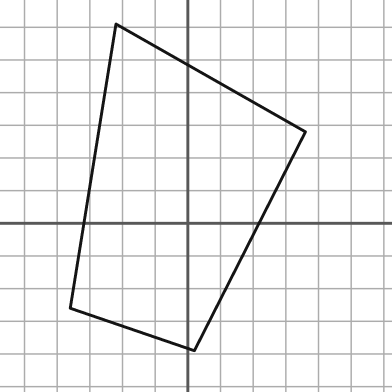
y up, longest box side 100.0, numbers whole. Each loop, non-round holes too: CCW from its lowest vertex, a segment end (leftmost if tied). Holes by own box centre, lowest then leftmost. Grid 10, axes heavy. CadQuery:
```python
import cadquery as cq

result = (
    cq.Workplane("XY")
    .moveTo(2.0, -39.0)
    .lineTo(36.0, 28.0)
    .lineTo(-22.0, 61.0)
    .lineTo(-36.0, -26.0)
    .close()
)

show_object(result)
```